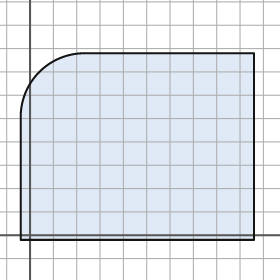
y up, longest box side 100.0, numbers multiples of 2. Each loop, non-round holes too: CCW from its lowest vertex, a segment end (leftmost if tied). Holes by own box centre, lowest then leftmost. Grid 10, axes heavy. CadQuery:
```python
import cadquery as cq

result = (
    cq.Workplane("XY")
    .moveTo(-4.0, -2.0)
    .lineTo(96.0, -2.0)
    .lineTo(96.0, 78.0)
    .lineTo(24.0, 78.0)
    .threePointArc((4.0, 70.0), (-4.0, 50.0))
    .close()
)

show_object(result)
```